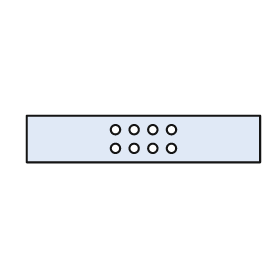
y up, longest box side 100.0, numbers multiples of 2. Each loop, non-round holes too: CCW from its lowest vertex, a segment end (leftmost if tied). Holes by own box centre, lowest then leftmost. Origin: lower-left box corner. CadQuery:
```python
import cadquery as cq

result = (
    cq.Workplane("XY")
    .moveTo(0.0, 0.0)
    .lineTo(100.0, 0.0)
    .lineTo(100.0, 20.0)
    .lineTo(0.0, 20.0)
    .close()
    .moveTo(38.0, 6.0)
    .circle(2.0)
    .moveTo(46.0, 6.0)
    .circle(2.0)
    .moveTo(54.0, 6.0)
    .circle(2.0)
    .moveTo(62.0, 6.0)
    .circle(2.0)
    .moveTo(38.0, 14.0)
    .circle(2.0)
    .moveTo(46.0, 14.0)
    .circle(2.0)
    .moveTo(54.0, 14.0)
    .circle(2.0)
    .moveTo(62.0, 14.0)
    .circle(2.0)
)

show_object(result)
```